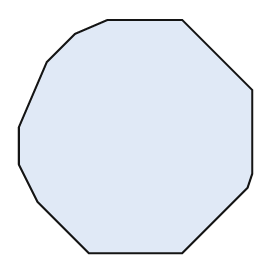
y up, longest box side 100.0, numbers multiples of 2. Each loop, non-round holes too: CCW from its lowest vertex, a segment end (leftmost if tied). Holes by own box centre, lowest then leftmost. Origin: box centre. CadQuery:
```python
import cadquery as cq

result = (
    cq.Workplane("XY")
    .moveTo(-20.0, -50.0)
    .lineTo(20.0, -50.0)
    .lineTo(48.0, -22.0)
    .lineTo(50.0, -16.0)
    .lineTo(50.0, 20.0)
    .lineTo(20.0, 50.0)
    .lineTo(-12.0, 50.0)
    .lineTo(-26.0, 44.0)
    .lineTo(-38.0, 32.0)
    .lineTo(-50.0, 4.0)
    .lineTo(-50.0, -12.0)
    .lineTo(-42.0, -28.0)
    .close()
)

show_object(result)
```